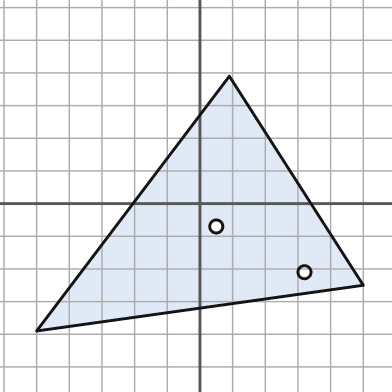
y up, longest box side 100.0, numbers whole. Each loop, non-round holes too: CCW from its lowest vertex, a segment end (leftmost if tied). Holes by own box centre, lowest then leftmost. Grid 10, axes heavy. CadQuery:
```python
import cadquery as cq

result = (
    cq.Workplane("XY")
    .moveTo(-50.0, -39.0)
    .lineTo(50.0, -25.0)
    .lineTo(9.0, 39.0)
    .close()
    .moveTo(32.0, -21.0)
    .circle(2.0)
    .moveTo(5.0, -7.0)
    .circle(2.0)
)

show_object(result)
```